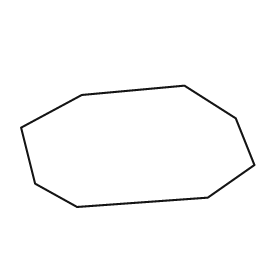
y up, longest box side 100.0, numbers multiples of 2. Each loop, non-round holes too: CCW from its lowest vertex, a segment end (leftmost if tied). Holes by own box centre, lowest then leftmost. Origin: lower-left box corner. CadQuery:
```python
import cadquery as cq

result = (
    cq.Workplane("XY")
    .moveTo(24.0, 0.0)
    .lineTo(80.0, 4.0)
    .lineTo(100.0, 18.0)
    .lineTo(92.0, 38.0)
    .lineTo(70.0, 52.0)
    .lineTo(26.0, 48.0)
    .lineTo(0.0, 34.0)
    .lineTo(6.0, 10.0)
    .close()
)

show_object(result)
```